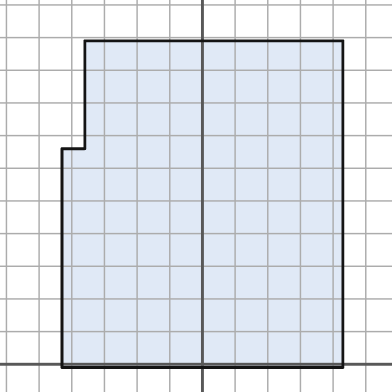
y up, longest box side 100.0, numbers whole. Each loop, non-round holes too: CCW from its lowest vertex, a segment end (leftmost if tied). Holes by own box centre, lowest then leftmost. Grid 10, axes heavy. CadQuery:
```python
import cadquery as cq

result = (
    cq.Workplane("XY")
    .moveTo(-43.0, -1.0)
    .lineTo(43.0, -1.0)
    .lineTo(43.0, 99.0)
    .lineTo(-36.0, 99.0)
    .lineTo(-36.0, 66.0)
    .lineTo(-43.0, 66.0)
    .close()
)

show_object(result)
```